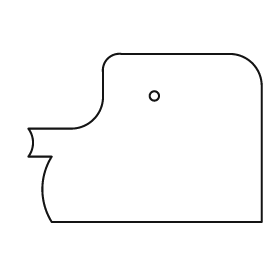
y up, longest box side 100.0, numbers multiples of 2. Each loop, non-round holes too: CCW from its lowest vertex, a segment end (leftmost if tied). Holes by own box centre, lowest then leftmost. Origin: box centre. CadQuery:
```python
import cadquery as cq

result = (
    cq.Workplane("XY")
    .moveTo(-40.0, -36.0)
    .lineTo(50.0, -36.0)
    .lineTo(50.0, 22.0)
    .threePointArc((46.0, 32.0), (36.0, 36.0))
    .lineTo(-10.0, 36.0)
    .threePointArc((-16.0, 34.0), (-18.0, 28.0))
    .lineTo(-18.0, 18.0)
    .threePointArc((-22.0, 8.0), (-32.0, 4.0))
    .lineTo(-50.0, 4.0)
    .threePointArc((-48.0, -2.0), (-50.0, -8.0))
    .lineTo(-40.0, -8.0)
    .threePointArc((-44.0, -22.0), (-40.0, -36.0))
    .close()
    .moveTo(4.0, 18.0)
    .circle(2.0)
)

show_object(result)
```